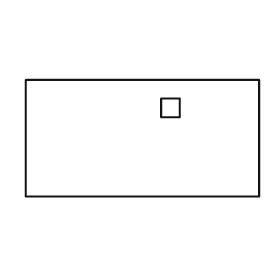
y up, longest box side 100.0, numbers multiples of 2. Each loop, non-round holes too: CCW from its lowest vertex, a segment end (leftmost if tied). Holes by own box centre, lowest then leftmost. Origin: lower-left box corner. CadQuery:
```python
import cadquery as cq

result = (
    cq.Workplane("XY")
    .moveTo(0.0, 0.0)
    .lineTo(100.0, 0.0)
    .lineTo(100.0, 50.0)
    .lineTo(0.0, 50.0)
    .close()
    .moveTo(58.0, 34.0)
    .lineTo(66.0, 34.0)
    .lineTo(66.0, 42.0)
    .lineTo(58.0, 42.0)
    .close()
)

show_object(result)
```